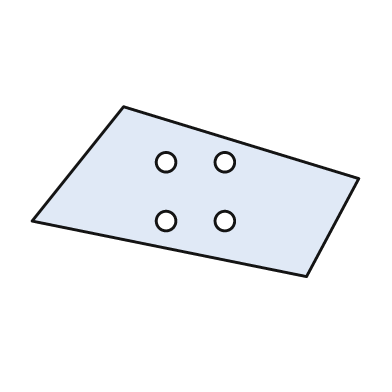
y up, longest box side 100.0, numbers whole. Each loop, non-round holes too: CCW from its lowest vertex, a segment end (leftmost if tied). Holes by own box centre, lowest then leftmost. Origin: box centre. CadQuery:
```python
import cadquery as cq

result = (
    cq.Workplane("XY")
    .moveTo(34.0, -26.0)
    .lineTo(50.0, 4.0)
    .lineTo(-22.0, 26.0)
    .lineTo(-50.0, -9.0)
    .close()
    .moveTo(-9.0, -9.0)
    .circle(3.0)
    .moveTo(9.0, -9.0)
    .circle(3.0)
    .moveTo(-9.0, 9.0)
    .circle(3.0)
    .moveTo(9.0, 9.0)
    .circle(3.0)
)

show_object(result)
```